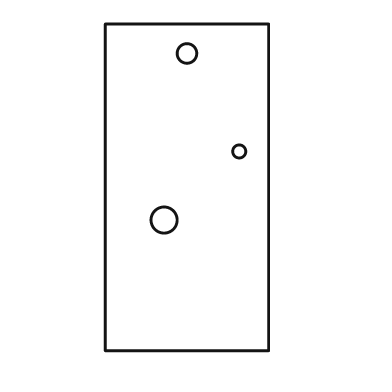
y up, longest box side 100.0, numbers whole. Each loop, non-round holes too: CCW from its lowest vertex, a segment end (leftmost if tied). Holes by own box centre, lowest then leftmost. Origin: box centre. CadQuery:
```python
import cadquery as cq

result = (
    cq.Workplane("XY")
    .moveTo(-25.0, -50.0)
    .lineTo(25.0, -50.0)
    .lineTo(25.0, 50.0)
    .lineTo(-25.0, 50.0)
    .close()
    .moveTo(-7.0, -10.0)
    .circle(4.0)
    .moveTo(16.0, 11.0)
    .circle(2.0)
    .moveTo(0.0, 41.0)
    .circle(3.0)
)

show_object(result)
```